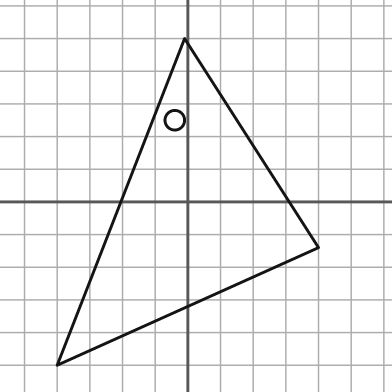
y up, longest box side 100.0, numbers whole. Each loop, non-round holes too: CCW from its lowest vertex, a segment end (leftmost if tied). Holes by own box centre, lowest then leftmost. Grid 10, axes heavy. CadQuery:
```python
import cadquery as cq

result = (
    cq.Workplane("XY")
    .moveTo(-40.0, -50.0)
    .lineTo(40.0, -14.0)
    .lineTo(-1.0, 50.0)
    .close()
    .moveTo(-4.0, 25.0)
    .circle(3.0)
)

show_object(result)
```